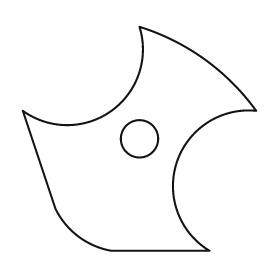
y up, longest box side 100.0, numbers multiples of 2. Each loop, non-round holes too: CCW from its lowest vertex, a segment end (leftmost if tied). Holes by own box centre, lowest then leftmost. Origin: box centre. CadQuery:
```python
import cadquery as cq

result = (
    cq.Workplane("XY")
    .moveTo(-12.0, -48.0)
    .lineTo(30.0, -48.0)
    .threePointArc((16.0, -10.0), (50.0, 12.0))
    .threePointArc((28.0, 34.0), (0.0, 48.0))
    .threePointArc((-12.0, 12.0), (-50.0, 12.0))
    .lineTo(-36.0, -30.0)
    .threePointArc((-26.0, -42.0), (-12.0, -48.0))
    .close()
    .moveTo(0.0, 0.0)
    .circle(8.0)
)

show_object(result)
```